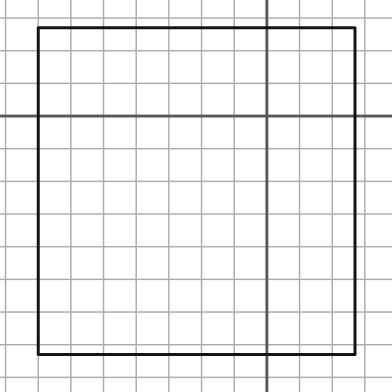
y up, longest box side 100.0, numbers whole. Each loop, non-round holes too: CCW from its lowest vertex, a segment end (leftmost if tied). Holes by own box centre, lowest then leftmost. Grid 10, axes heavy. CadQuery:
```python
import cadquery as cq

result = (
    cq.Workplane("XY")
    .moveTo(-70.0, -73.0)
    .lineTo(27.0, -73.0)
    .lineTo(27.0, 27.0)
    .lineTo(-70.0, 27.0)
    .close()
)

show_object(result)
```